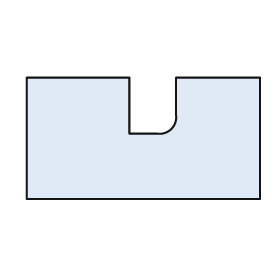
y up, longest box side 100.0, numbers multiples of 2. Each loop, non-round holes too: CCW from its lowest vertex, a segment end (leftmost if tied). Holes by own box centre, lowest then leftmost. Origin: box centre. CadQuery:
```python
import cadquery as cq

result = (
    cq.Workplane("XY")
    .moveTo(-50.0, -26.0)
    .lineTo(50.0, -26.0)
    .lineTo(50.0, 26.0)
    .lineTo(14.0, 26.0)
    .lineTo(14.0, 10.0)
    .threePointArc((12.0, 4.0), (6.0, 2.0))
    .lineTo(-6.0, 2.0)
    .lineTo(-6.0, 26.0)
    .lineTo(-50.0, 26.0)
    .close()
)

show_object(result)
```